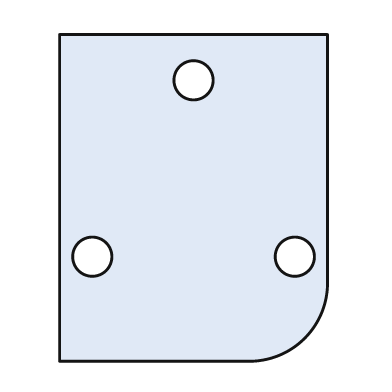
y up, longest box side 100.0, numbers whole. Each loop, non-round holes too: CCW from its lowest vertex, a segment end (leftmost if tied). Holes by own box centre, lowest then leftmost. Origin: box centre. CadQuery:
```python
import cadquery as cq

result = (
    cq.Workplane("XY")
    .moveTo(-41.0, -50.0)
    .lineTo(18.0, -50.0)
    .threePointArc((34.0, -43.0), (41.0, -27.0))
    .lineTo(41.0, 50.0)
    .lineTo(-41.0, 50.0)
    .close()
    .moveTo(-31.0, -18.0)
    .circle(6.0)
    .moveTo(31.0, -18.0)
    .circle(6.0)
    .moveTo(0.0, 36.0)
    .circle(6.0)
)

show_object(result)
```